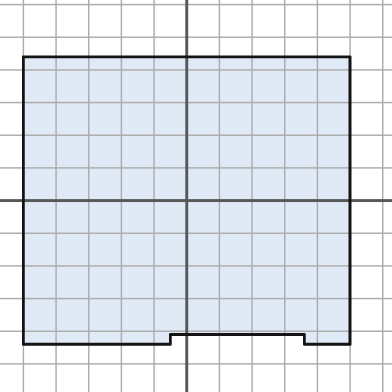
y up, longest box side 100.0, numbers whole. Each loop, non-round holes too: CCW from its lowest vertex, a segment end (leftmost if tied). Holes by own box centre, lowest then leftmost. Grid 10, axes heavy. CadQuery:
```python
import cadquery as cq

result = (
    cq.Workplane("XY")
    .moveTo(-50.0, -44.0)
    .lineTo(-5.0, -44.0)
    .lineTo(-5.0, -41.0)
    .lineTo(36.0, -41.0)
    .lineTo(36.0, -44.0)
    .lineTo(50.0, -44.0)
    .lineTo(50.0, 44.0)
    .lineTo(-50.0, 44.0)
    .close()
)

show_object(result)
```